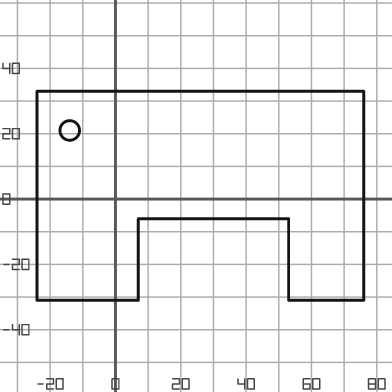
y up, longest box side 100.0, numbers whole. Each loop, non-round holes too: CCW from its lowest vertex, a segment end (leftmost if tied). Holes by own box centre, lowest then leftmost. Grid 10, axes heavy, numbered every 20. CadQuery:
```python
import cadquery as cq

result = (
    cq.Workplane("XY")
    .moveTo(-24.0, -31.0)
    .lineTo(7.0, -31.0)
    .lineTo(7.0, -6.0)
    .lineTo(53.0, -6.0)
    .lineTo(53.0, -31.0)
    .lineTo(76.0, -31.0)
    .lineTo(76.0, 33.0)
    .lineTo(-24.0, 33.0)
    .close()
    .moveTo(-14.0, 21.0)
    .circle(3.0)
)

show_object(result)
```